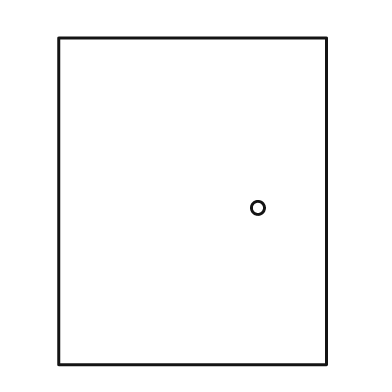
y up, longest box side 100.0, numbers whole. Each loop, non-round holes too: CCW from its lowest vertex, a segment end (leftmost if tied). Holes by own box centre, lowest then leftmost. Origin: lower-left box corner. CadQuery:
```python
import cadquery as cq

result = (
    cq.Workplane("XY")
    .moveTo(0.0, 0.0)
    .lineTo(82.0, 0.0)
    .lineTo(82.0, 100.0)
    .lineTo(0.0, 100.0)
    .close()
    .moveTo(61.0, 48.0)
    .circle(2.0)
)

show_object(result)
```